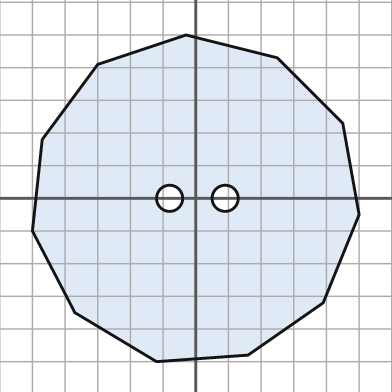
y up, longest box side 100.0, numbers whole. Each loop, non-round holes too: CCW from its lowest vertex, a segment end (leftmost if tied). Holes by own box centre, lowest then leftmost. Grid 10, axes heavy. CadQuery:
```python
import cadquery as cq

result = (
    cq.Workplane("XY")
    .moveTo(-12.0, -50.0)
    .lineTo(16.0, -48.0)
    .lineTo(39.0, -32.0)
    .lineTo(50.0, -5.0)
    .lineTo(45.0, 23.0)
    .lineTo(25.0, 43.0)
    .lineTo(-3.0, 50.0)
    .lineTo(-30.0, 41.0)
    .lineTo(-47.0, 18.0)
    .lineTo(-50.0, -10.0)
    .lineTo(-37.0, -35.0)
    .close()
    .moveTo(-8.0, 0.0)
    .circle(4.0)
    .moveTo(9.0, 0.0)
    .circle(4.0)
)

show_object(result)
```